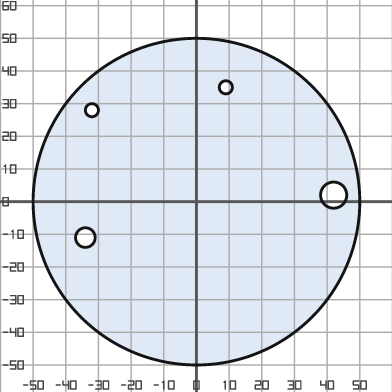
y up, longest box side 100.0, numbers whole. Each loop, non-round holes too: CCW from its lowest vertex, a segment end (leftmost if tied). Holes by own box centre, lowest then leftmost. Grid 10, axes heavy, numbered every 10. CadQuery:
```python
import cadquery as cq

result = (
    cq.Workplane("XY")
    .moveTo(0.0, 0.0)
    .circle(50.0)
    .moveTo(-34.0, -11.0)
    .circle(3.0)
    .moveTo(42.0, 2.0)
    .circle(4.0)
    .moveTo(-32.0, 28.0)
    .circle(2.0)
    .moveTo(9.0, 35.0)
    .circle(2.0)
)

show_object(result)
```